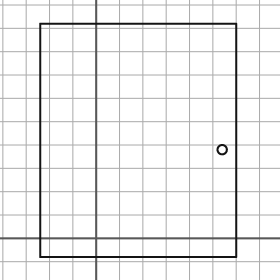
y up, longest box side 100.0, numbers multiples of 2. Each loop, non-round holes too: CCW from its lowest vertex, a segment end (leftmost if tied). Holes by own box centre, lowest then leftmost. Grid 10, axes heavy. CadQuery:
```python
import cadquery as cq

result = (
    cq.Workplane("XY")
    .moveTo(-24.0, -8.0)
    .lineTo(60.0, -8.0)
    .lineTo(60.0, 92.0)
    .lineTo(-24.0, 92.0)
    .close()
    .moveTo(54.0, 38.0)
    .circle(2.0)
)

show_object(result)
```